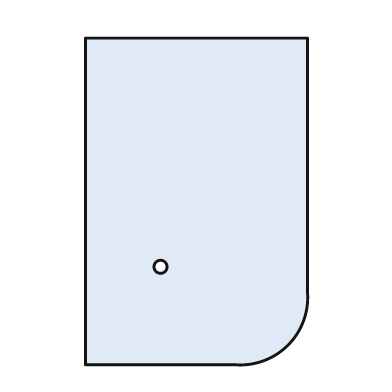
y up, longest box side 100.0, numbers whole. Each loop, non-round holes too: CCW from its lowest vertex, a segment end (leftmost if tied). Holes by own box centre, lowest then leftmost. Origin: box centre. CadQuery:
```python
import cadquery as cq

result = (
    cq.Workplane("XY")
    .moveTo(-34.0, -50.0)
    .lineTo(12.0, -50.0)
    .threePointArc((28.0, -44.0), (34.0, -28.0))
    .lineTo(34.0, 50.0)
    .lineTo(-34.0, 50.0)
    .close()
    .moveTo(-11.0, -20.0)
    .circle(2.0)
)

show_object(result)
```